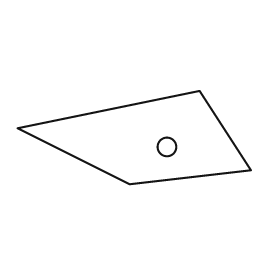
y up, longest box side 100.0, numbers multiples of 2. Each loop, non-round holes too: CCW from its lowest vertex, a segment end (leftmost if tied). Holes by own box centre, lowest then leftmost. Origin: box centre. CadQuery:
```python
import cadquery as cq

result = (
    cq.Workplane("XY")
    .moveTo(-2.0, -20.0)
    .lineTo(50.0, -14.0)
    .lineTo(28.0, 20.0)
    .lineTo(-50.0, 4.0)
    .close()
    .moveTo(14.0, -4.0)
    .circle(4.0)
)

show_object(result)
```